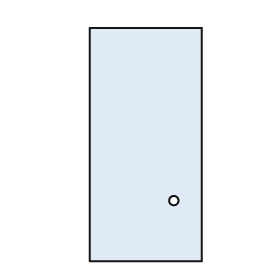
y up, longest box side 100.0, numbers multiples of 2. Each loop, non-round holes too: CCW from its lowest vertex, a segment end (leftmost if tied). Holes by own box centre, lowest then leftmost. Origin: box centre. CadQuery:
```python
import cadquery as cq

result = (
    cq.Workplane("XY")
    .moveTo(-24.0, -50.0)
    .lineTo(24.0, -50.0)
    .lineTo(24.0, 50.0)
    .lineTo(-24.0, 50.0)
    .close()
    .moveTo(12.0, -24.0)
    .circle(2.0)
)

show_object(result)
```